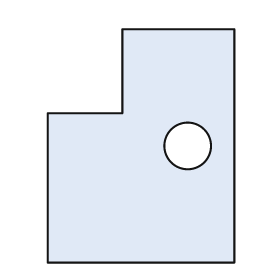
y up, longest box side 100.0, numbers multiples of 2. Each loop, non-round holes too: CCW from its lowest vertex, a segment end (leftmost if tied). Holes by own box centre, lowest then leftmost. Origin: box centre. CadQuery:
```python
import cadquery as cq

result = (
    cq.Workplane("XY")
    .moveTo(-40.0, -50.0)
    .lineTo(40.0, -50.0)
    .lineTo(40.0, 50.0)
    .lineTo(-8.0, 50.0)
    .lineTo(-8.0, 14.0)
    .lineTo(-40.0, 14.0)
    .close()
    .moveTo(20.0, 0.0)
    .circle(10.0)
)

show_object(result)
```